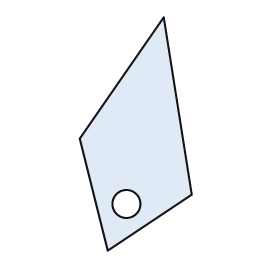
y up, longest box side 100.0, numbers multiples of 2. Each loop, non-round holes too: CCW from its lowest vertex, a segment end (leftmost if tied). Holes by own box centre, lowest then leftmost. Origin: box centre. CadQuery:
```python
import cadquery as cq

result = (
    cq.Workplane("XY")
    .moveTo(-12.0, -50.0)
    .lineTo(24.0, -26.0)
    .lineTo(12.0, 50.0)
    .lineTo(-24.0, -2.0)
    .close()
    .moveTo(-4.0, -30.0)
    .circle(6.0)
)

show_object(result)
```